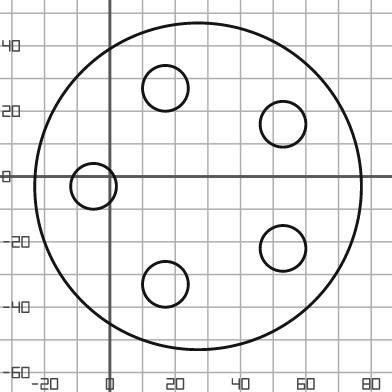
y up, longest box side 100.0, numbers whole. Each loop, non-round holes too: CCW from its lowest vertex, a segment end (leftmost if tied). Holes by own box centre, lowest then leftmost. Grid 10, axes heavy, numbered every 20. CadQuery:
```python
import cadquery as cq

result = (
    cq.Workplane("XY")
    .moveTo(27.0, -3.0)
    .circle(50.0)
    .moveTo(17.0, -33.0)
    .circle(7.0)
    .moveTo(53.0, -22.0)
    .circle(7.0)
    .moveTo(-5.0, -3.0)
    .circle(7.0)
    .moveTo(53.0, 16.0)
    .circle(7.0)
    .moveTo(17.0, 27.0)
    .circle(7.0)
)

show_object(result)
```